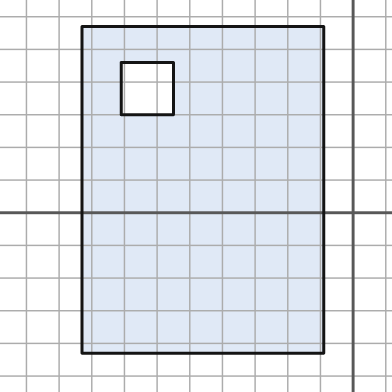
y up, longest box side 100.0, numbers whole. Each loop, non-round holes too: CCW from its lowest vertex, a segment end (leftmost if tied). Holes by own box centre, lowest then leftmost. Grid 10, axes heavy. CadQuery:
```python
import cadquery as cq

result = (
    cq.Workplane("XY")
    .moveTo(-83.0, -43.0)
    .lineTo(-9.0, -43.0)
    .lineTo(-9.0, 57.0)
    .lineTo(-83.0, 57.0)
    .close()
    .moveTo(-71.0, 30.0)
    .lineTo(-55.0, 30.0)
    .lineTo(-55.0, 46.0)
    .lineTo(-71.0, 46.0)
    .close()
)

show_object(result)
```